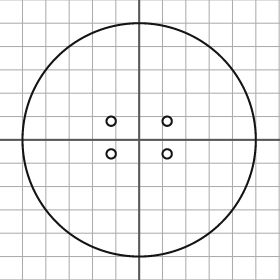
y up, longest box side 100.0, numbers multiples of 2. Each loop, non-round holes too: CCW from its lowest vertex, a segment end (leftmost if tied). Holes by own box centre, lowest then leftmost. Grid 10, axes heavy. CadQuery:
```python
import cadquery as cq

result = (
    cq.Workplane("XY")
    .moveTo(0.0, 0.0)
    .circle(50.0)
    .moveTo(-12.0, -6.0)
    .circle(2.0)
    .moveTo(12.0, -6.0)
    .circle(2.0)
    .moveTo(-12.0, 8.0)
    .circle(2.0)
    .moveTo(12.0, 8.0)
    .circle(2.0)
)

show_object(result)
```